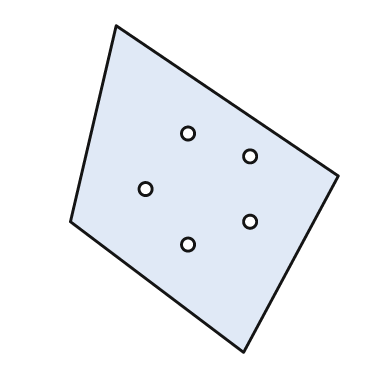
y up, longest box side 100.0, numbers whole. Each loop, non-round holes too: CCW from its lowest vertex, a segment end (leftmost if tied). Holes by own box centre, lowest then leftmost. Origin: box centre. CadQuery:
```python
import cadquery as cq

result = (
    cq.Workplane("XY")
    .moveTo(12.0, -50.0)
    .lineTo(41.0, 4.0)
    .lineTo(-27.0, 50.0)
    .lineTo(-41.0, -10.0)
    .close()
    .moveTo(-5.0, -17.0)
    .circle(2.0)
    .moveTo(14.0, -10.0)
    .circle(2.0)
    .moveTo(-18.0, 0.0)
    .circle(2.0)
    .moveTo(14.0, 10.0)
    .circle(2.0)
    .moveTo(-5.0, 17.0)
    .circle(2.0)
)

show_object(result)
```